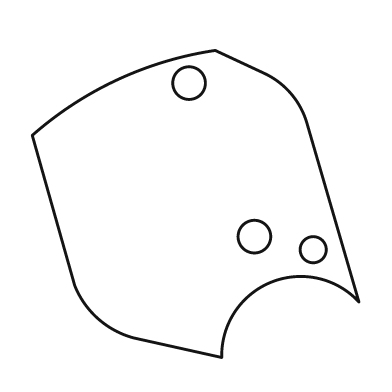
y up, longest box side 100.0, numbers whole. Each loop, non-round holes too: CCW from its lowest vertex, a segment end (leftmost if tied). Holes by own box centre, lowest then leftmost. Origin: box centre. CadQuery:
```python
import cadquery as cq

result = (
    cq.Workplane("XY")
    .moveTo(8.0, -47.0)
    .threePointArc((23.0, -24.0), (50.0, -30.0))
    .lineTo(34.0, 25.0)
    .threePointArc((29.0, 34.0), (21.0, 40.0))
    .lineTo(6.0, 47.0)
    .threePointArc((-24.0, 38.0), (-50.0, 21.0))
    .lineTo(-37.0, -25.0)
    .threePointArc((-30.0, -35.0), (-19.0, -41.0))
    .close()
    .moveTo(36.0, -14.0)
    .circle(4.0)
    .moveTo(18.0, -10.0)
    .circle(5.0)
    .moveTo(-2.0, 37.0)
    .circle(5.0)
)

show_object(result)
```